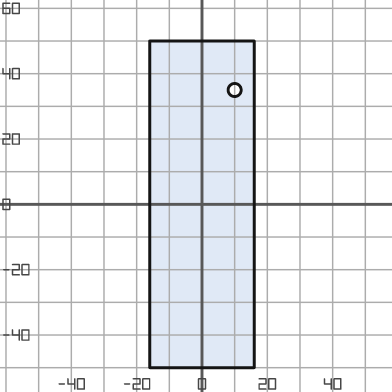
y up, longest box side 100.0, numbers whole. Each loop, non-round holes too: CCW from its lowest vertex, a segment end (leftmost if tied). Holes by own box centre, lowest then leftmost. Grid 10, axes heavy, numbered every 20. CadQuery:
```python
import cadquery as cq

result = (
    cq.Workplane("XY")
    .moveTo(-16.0, -50.0)
    .lineTo(16.0, -50.0)
    .lineTo(16.0, 50.0)
    .lineTo(-16.0, 50.0)
    .close()
    .moveTo(10.0, 35.0)
    .circle(2.0)
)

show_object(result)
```